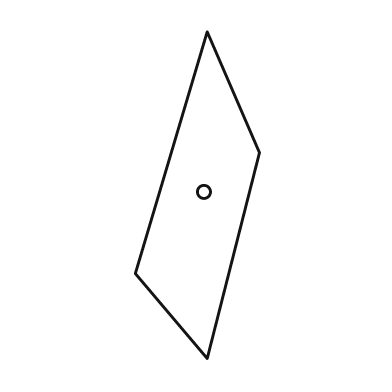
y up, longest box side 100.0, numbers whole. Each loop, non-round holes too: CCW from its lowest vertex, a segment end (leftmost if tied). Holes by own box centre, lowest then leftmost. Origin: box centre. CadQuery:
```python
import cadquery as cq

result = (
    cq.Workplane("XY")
    .moveTo(3.0, -50.0)
    .lineTo(19.0, 13.0)
    .lineTo(3.0, 50.0)
    .lineTo(-19.0, -24.0)
    .close()
    .moveTo(2.0, 1.0)
    .circle(2.0)
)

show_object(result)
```